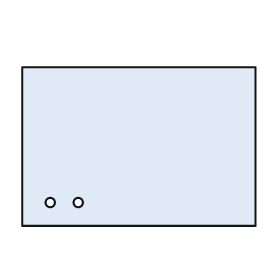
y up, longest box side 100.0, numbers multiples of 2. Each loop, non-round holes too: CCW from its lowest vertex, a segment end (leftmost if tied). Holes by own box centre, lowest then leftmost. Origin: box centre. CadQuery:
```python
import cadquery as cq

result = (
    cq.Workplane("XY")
    .moveTo(-50.0, -34.0)
    .lineTo(50.0, -34.0)
    .lineTo(50.0, 34.0)
    .lineTo(-50.0, 34.0)
    .close()
    .moveTo(-38.0, -24.0)
    .circle(2.0)
    .moveTo(-26.0, -24.0)
    .circle(2.0)
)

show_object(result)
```